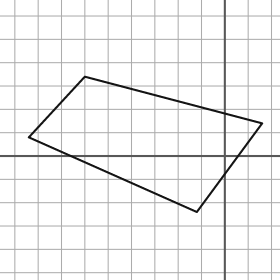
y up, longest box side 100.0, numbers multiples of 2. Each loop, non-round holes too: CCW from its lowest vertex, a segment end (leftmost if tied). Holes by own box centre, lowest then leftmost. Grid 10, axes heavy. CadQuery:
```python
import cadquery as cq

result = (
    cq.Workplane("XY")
    .moveTo(-12.0, -24.0)
    .lineTo(16.0, 14.0)
    .lineTo(-60.0, 34.0)
    .lineTo(-84.0, 8.0)
    .close()
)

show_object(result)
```